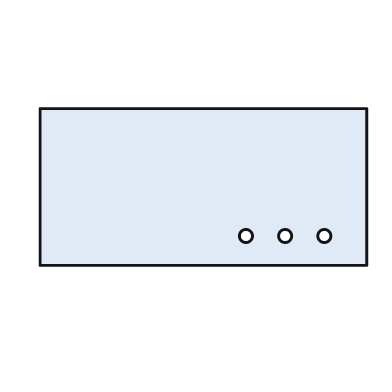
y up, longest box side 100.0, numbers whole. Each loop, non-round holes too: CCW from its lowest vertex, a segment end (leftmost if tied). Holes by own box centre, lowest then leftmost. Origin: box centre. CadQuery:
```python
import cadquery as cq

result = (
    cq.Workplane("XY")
    .moveTo(-50.0, -24.0)
    .lineTo(50.0, -24.0)
    .lineTo(50.0, 24.0)
    .lineTo(-50.0, 24.0)
    .close()
    .moveTo(13.0, -15.0)
    .circle(2.0)
    .moveTo(25.0, -15.0)
    .circle(2.0)
    .moveTo(37.0, -15.0)
    .circle(2.0)
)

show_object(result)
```